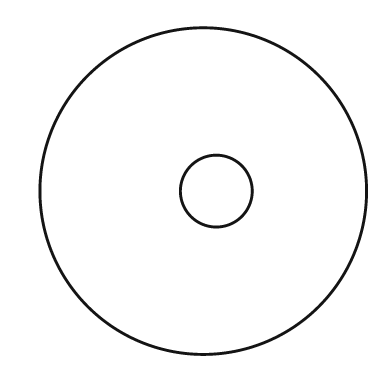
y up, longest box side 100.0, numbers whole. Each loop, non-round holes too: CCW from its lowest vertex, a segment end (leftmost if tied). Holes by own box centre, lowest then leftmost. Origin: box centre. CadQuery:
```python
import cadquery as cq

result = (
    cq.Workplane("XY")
    .moveTo(0.0, 0.0)
    .circle(50.0)
    .moveTo(4.0, 0.0)
    .circle(11.0)
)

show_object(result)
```